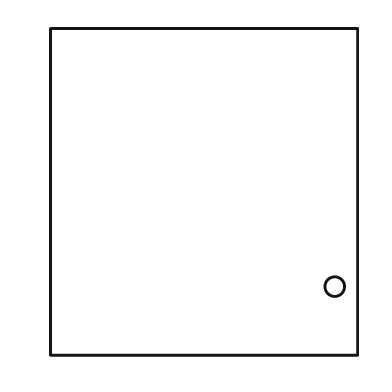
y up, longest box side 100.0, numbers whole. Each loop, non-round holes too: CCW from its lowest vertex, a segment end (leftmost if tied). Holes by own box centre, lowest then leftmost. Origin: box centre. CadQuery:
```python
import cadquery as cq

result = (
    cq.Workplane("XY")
    .moveTo(-47.0, -50.0)
    .lineTo(47.0, -50.0)
    .lineTo(47.0, 50.0)
    .lineTo(-47.0, 50.0)
    .close()
    .moveTo(40.0, -29.0)
    .circle(3.0)
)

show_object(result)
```